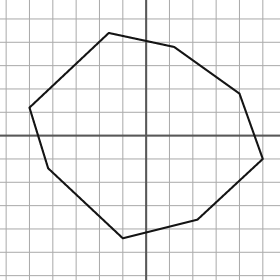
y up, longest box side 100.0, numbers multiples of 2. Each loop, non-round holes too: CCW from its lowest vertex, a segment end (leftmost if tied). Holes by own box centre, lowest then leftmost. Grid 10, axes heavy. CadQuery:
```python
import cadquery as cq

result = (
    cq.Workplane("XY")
    .moveTo(-10.0, -44.0)
    .lineTo(22.0, -36.0)
    .lineTo(50.0, -10.0)
    .lineTo(40.0, 18.0)
    .lineTo(12.0, 38.0)
    .lineTo(-16.0, 44.0)
    .lineTo(-50.0, 12.0)
    .lineTo(-42.0, -14.0)
    .close()
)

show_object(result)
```